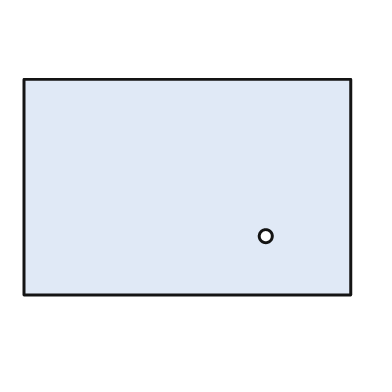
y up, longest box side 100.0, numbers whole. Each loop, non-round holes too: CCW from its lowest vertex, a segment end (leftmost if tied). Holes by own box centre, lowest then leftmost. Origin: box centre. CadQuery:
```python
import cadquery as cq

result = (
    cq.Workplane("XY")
    .moveTo(-50.0, -33.0)
    .lineTo(50.0, -33.0)
    .lineTo(50.0, 33.0)
    .lineTo(-50.0, 33.0)
    .close()
    .moveTo(24.0, -15.0)
    .circle(2.0)
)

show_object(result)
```